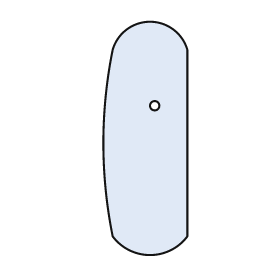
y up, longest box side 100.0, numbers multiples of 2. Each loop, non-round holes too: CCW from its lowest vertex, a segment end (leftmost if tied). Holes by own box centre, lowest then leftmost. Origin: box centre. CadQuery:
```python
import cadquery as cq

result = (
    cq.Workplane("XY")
    .moveTo(-14.0, -42.0)
    .threePointArc((2.0, -50.0), (18.0, -42.0))
    .lineTo(18.0, 38.0)
    .threePointArc((2.0, 50.0), (-14.0, 38.0))
    .threePointArc((-18.0, -2.0), (-14.0, -42.0))
    .close()
    .moveTo(4.0, 14.0)
    .circle(2.0)
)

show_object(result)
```